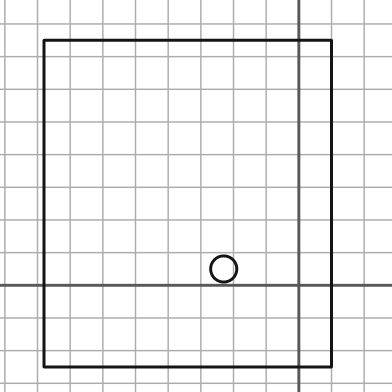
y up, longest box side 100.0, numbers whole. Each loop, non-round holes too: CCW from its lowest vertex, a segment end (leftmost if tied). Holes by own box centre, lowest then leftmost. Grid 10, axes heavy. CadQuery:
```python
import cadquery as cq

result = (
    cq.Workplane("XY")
    .moveTo(-78.0, -25.0)
    .lineTo(10.0, -25.0)
    .lineTo(10.0, 75.0)
    .lineTo(-78.0, 75.0)
    .close()
    .moveTo(-23.0, 5.0)
    .circle(4.0)
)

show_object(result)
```